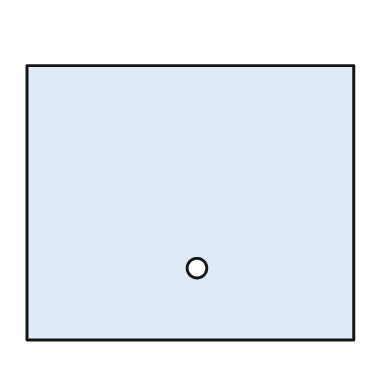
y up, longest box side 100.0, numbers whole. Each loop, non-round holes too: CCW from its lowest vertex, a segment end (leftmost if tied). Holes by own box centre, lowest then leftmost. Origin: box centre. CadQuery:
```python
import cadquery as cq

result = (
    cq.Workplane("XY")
    .moveTo(-50.0, -42.0)
    .lineTo(50.0, -42.0)
    .lineTo(50.0, 42.0)
    .lineTo(-50.0, 42.0)
    .close()
    .moveTo(2.0, -20.0)
    .circle(3.0)
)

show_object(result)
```